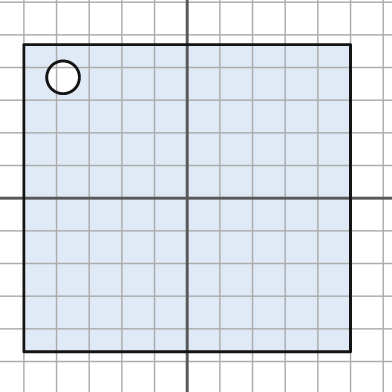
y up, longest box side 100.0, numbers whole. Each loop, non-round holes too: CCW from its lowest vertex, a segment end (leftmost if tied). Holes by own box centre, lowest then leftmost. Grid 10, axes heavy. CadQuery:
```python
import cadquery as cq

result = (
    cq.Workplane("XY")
    .moveTo(-50.0, -47.0)
    .lineTo(50.0, -47.0)
    .lineTo(50.0, 47.0)
    .lineTo(-50.0, 47.0)
    .close()
    .moveTo(-38.0, 37.0)
    .circle(5.0)
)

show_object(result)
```